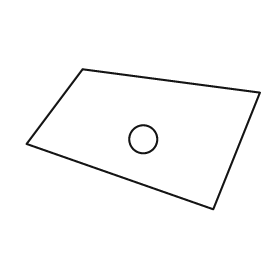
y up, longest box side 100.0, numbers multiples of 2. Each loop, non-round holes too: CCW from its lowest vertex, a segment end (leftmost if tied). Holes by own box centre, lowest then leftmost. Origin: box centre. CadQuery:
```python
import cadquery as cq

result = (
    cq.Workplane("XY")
    .moveTo(30.0, -30.0)
    .lineTo(50.0, 20.0)
    .lineTo(-26.0, 30.0)
    .lineTo(-50.0, -2.0)
    .close()
    .moveTo(0.0, 0.0)
    .circle(6.0)
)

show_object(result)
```